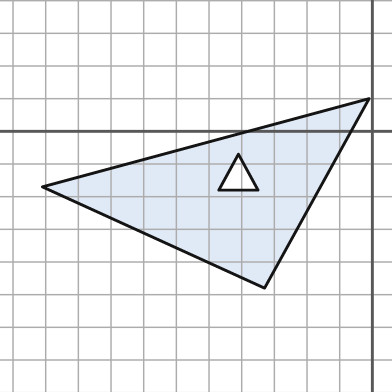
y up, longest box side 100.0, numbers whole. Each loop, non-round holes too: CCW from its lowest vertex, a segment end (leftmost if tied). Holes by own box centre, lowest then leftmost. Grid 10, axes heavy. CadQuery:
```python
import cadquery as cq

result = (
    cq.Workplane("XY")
    .moveTo(-33.0, -48.0)
    .lineTo(-1.0, 10.0)
    .lineTo(-101.0, -17.0)
    .close()
    .moveTo(-47.0, -18.0)
    .lineTo(-35.0, -18.0)
    .lineTo(-41.0, -7.0)
    .close()
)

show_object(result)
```